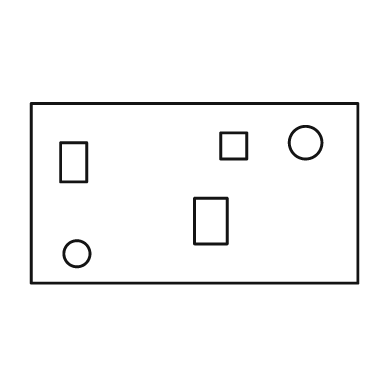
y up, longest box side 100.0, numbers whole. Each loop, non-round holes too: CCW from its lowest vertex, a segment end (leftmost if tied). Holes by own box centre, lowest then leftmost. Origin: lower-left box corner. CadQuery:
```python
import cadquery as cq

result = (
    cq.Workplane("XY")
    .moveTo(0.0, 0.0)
    .lineTo(100.0, 0.0)
    .lineTo(100.0, 55.0)
    .lineTo(0.0, 55.0)
    .close()
    .moveTo(14.0, 9.0)
    .circle(4.0)
    .moveTo(50.0, 12.0)
    .lineTo(60.0, 12.0)
    .lineTo(60.0, 26.0)
    .lineTo(50.0, 26.0)
    .close()
    .moveTo(9.0, 31.0)
    .lineTo(17.0, 31.0)
    .lineTo(17.0, 43.0)
    .lineTo(9.0, 43.0)
    .close()
    .moveTo(58.0, 38.0)
    .lineTo(66.0, 38.0)
    .lineTo(66.0, 46.0)
    .lineTo(58.0, 46.0)
    .close()
    .moveTo(84.0, 43.0)
    .circle(5.0)
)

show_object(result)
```